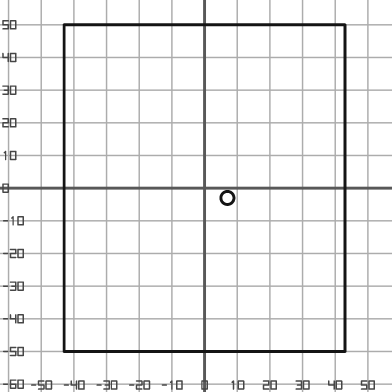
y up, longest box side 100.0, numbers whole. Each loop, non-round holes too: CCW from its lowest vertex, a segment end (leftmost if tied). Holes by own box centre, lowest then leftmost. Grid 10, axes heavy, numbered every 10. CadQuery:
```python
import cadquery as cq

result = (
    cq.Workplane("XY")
    .moveTo(-43.0, -50.0)
    .lineTo(43.0, -50.0)
    .lineTo(43.0, 50.0)
    .lineTo(-43.0, 50.0)
    .close()
    .moveTo(7.0, -3.0)
    .circle(2.0)
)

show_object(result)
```